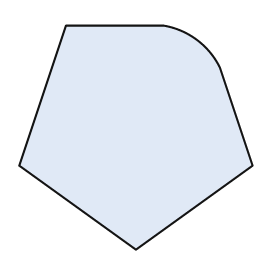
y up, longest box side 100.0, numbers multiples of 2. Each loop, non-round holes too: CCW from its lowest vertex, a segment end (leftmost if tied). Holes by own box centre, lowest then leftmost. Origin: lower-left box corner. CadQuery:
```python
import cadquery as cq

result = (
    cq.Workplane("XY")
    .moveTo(50.0, 0.0)
    .lineTo(100.0, 36.0)
    .lineTo(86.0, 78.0)
    .threePointArc((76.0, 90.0), (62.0, 96.0))
    .lineTo(20.0, 96.0)
    .lineTo(0.0, 36.0)
    .close()
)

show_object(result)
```